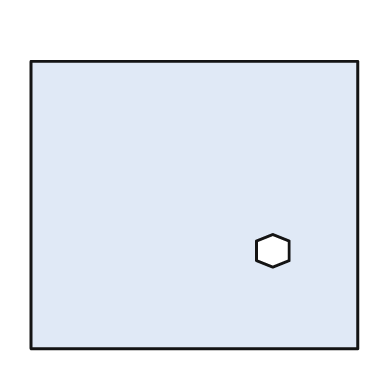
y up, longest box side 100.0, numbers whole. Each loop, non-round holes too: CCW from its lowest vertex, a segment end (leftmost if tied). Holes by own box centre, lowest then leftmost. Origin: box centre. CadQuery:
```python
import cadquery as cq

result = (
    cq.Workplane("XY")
    .moveTo(-50.0, -44.0)
    .lineTo(50.0, -44.0)
    .lineTo(50.0, 44.0)
    .lineTo(-50.0, 44.0)
    .close()
    .moveTo(24.0, -19.0)
    .lineTo(29.0, -17.0)
    .lineTo(29.0, -11.0)
    .lineTo(24.0, -9.0)
    .lineTo(19.0, -11.0)
    .lineTo(19.0, -17.0)
    .close()
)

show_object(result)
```